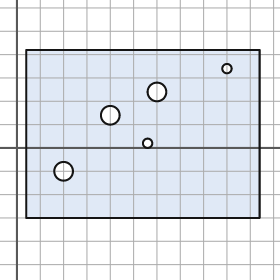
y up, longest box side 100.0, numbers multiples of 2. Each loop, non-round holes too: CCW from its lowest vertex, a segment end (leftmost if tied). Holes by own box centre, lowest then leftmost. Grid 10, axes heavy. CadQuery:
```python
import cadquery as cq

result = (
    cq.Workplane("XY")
    .moveTo(4.0, -30.0)
    .lineTo(104.0, -30.0)
    .lineTo(104.0, 42.0)
    .lineTo(4.0, 42.0)
    .close()
    .moveTo(20.0, -10.0)
    .circle(4.0)
    .moveTo(56.0, 2.0)
    .circle(2.0)
    .moveTo(40.0, 14.0)
    .circle(4.0)
    .moveTo(60.0, 24.0)
    .circle(4.0)
    .moveTo(90.0, 34.0)
    .circle(2.0)
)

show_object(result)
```